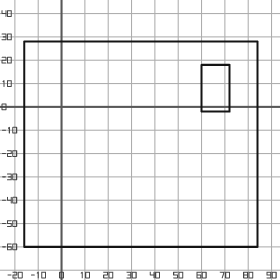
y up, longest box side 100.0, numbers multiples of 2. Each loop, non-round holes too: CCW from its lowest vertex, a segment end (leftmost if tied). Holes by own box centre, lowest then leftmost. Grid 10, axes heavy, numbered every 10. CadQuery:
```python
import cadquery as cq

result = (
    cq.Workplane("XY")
    .moveTo(-16.0, -60.0)
    .lineTo(84.0, -60.0)
    .lineTo(84.0, 28.0)
    .lineTo(-16.0, 28.0)
    .close()
    .moveTo(60.0, -2.0)
    .lineTo(72.0, -2.0)
    .lineTo(72.0, 18.0)
    .lineTo(60.0, 18.0)
    .close()
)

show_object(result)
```